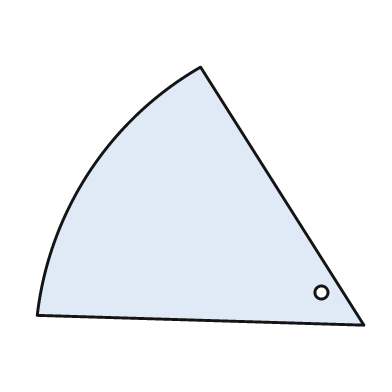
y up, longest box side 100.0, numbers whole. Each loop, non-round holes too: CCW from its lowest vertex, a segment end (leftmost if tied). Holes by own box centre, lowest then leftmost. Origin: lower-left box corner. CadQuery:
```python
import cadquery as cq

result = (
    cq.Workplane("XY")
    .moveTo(100.0, 0.0)
    .lineTo(50.0, 79.0)
    .threePointArc((16.0, 47.0), (0.0, 3.0))
    .close()
    .moveTo(87.0, 10.0)
    .circle(2.0)
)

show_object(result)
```